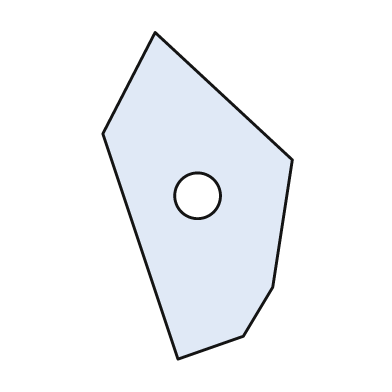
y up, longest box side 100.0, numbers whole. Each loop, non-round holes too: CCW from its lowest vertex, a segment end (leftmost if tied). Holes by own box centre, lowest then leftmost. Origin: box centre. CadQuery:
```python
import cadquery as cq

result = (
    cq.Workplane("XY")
    .moveTo(-6.0, -50.0)
    .lineTo(14.0, -43.0)
    .lineTo(23.0, -28.0)
    .lineTo(29.0, 11.0)
    .lineTo(-13.0, 50.0)
    .lineTo(-29.0, 19.0)
    .close()
    .moveTo(0.0, 0.0)
    .circle(7.0)
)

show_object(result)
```